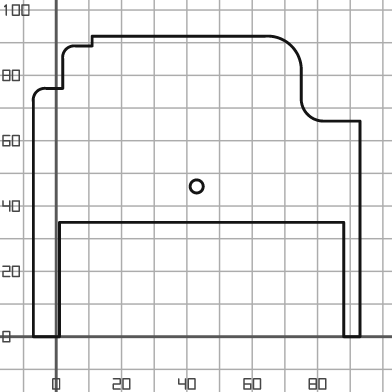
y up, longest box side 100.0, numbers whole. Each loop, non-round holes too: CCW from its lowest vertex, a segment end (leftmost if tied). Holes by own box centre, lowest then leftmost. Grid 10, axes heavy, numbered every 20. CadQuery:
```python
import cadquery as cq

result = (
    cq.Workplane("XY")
    .moveTo(-7.0, 0.0)
    .lineTo(1.0, 0.0)
    .lineTo(1.0, 35.0)
    .lineTo(88.0, 35.0)
    .lineTo(88.0, 0.0)
    .lineTo(93.0, 0.0)
    .lineTo(93.0, 66.0)
    .lineTo(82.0, 66.0)
    .threePointArc((77.0, 68.0), (75.0, 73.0))
    .lineTo(75.0, 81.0)
    .threePointArc((72.0, 89.0), (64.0, 92.0))
    .lineTo(11.0, 92.0)
    .lineTo(11.0, 89.0)
    .lineTo(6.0, 89.0)
    .threePointArc((3.0, 88.0), (2.0, 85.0))
    .lineTo(2.0, 76.0)
    .lineTo(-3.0, 76.0)
    .threePointArc((-6.0, 75.0), (-7.0, 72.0))
    .close()
    .moveTo(43.0, 46.0)
    .circle(2.0)
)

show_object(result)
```